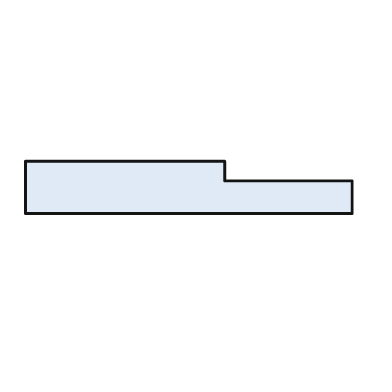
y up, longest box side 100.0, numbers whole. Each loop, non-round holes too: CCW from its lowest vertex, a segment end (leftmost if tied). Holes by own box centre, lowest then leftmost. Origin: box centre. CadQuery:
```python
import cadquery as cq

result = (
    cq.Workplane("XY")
    .moveTo(-50.0, -8.0)
    .lineTo(50.0, -8.0)
    .lineTo(50.0, 2.0)
    .lineTo(11.0, 2.0)
    .lineTo(11.0, 8.0)
    .lineTo(-50.0, 8.0)
    .close()
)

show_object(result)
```